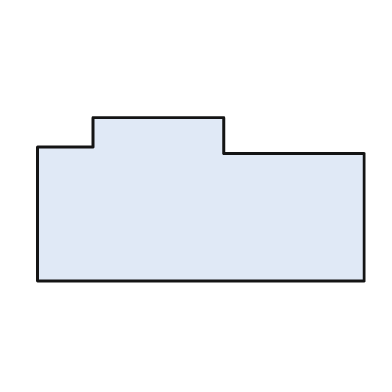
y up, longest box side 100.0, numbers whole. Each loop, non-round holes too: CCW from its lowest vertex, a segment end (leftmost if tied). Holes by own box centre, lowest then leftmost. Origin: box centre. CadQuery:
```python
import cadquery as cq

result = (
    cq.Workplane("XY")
    .moveTo(-50.0, -25.0)
    .lineTo(50.0, -25.0)
    .lineTo(50.0, 14.0)
    .lineTo(7.0, 14.0)
    .lineTo(7.0, 25.0)
    .lineTo(-33.0, 25.0)
    .lineTo(-33.0, 16.0)
    .lineTo(-50.0, 16.0)
    .close()
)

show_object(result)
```